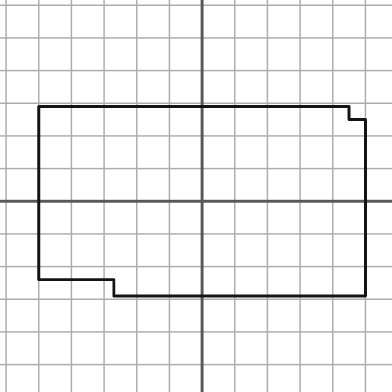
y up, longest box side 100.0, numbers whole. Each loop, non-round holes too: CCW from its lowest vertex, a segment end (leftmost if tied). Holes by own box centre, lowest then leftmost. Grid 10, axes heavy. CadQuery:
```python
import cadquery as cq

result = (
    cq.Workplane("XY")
    .moveTo(-27.0, -29.0)
    .lineTo(50.0, -29.0)
    .lineTo(50.0, 25.0)
    .lineTo(45.0, 25.0)
    .lineTo(45.0, 29.0)
    .lineTo(-50.0, 29.0)
    .lineTo(-50.0, -24.0)
    .lineTo(-27.0, -24.0)
    .close()
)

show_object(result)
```